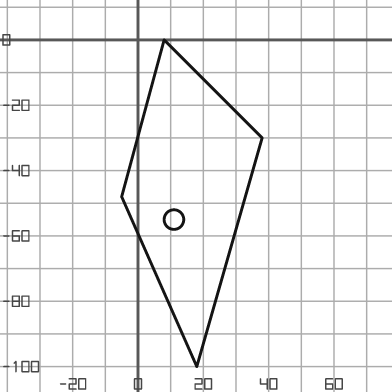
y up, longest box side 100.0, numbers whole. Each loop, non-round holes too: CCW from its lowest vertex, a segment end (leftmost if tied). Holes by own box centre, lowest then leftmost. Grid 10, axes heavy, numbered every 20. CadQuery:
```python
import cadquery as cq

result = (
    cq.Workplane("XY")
    .moveTo(18.0, -100.0)
    .lineTo(38.0, -30.0)
    .lineTo(8.0, 0.0)
    .lineTo(-5.0, -48.0)
    .close()
    .moveTo(11.0, -55.0)
    .circle(3.0)
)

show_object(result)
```